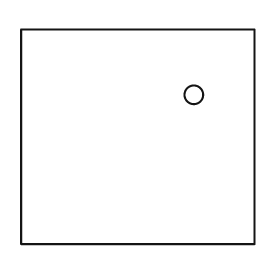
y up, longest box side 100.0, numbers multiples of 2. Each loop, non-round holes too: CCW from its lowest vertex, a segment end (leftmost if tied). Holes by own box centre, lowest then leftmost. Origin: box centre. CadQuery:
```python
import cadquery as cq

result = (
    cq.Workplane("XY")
    .moveTo(-50.0, -46.0)
    .lineTo(50.0, -46.0)
    .lineTo(50.0, 46.0)
    .lineTo(-50.0, 46.0)
    .close()
    .moveTo(24.0, 18.0)
    .circle(4.0)
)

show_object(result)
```